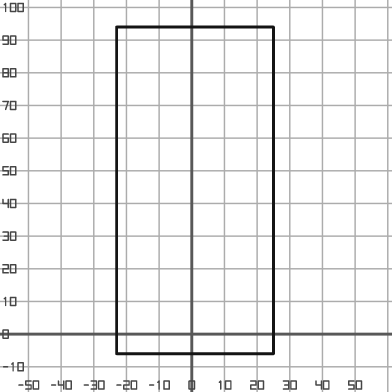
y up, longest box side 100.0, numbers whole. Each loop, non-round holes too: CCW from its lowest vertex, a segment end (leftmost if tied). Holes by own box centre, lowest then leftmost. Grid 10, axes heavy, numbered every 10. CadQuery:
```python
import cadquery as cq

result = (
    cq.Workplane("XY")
    .moveTo(-23.0, -6.0)
    .lineTo(25.0, -6.0)
    .lineTo(25.0, 94.0)
    .lineTo(-23.0, 94.0)
    .close()
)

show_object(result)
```